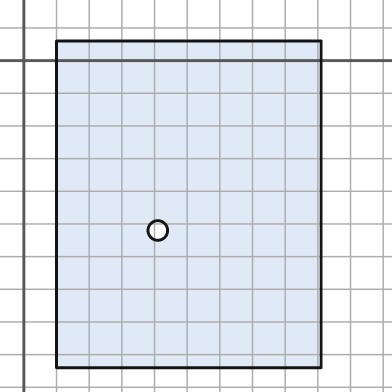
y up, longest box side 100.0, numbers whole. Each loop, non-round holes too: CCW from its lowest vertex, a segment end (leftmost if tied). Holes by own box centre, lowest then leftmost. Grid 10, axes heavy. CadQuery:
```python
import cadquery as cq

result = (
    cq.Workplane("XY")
    .moveTo(10.0, -94.0)
    .lineTo(91.0, -94.0)
    .lineTo(91.0, 6.0)
    .lineTo(10.0, 6.0)
    .close()
    .moveTo(41.0, -52.0)
    .circle(3.0)
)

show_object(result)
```